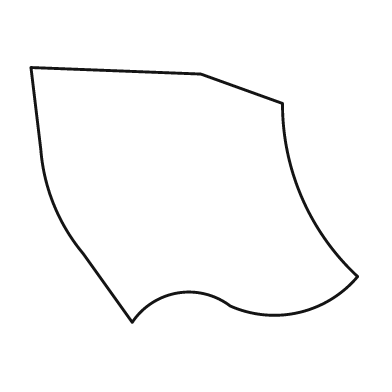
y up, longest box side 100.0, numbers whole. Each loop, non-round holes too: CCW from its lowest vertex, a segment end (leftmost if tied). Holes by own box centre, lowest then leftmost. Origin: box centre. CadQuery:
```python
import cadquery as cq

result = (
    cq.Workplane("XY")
    .moveTo(-19.0, -39.0)
    .threePointArc((-5.0, -30.0), (11.0, -34.0))
    .threePointArc((32.0, -36.0), (50.0, -25.0))
    .threePointArc((33.0, -1.0), (27.0, 28.0))
    .lineTo(2.0, 37.0)
    .lineTo(-50.0, 39.0)
    .lineTo(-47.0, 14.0)
    .threePointArc((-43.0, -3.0), (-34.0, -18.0))
    .close()
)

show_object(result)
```